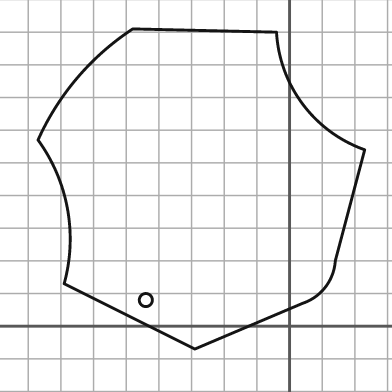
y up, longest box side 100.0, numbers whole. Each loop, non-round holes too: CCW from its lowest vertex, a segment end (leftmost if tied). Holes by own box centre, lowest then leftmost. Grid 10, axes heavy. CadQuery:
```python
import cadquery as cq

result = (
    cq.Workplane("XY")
    .moveTo(-29.0, -7.0)
    .lineTo(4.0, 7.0)
    .threePointArc((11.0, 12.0), (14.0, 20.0))
    .lineTo(23.0, 54.0)
    .threePointArc((4.0, 68.0), (-4.0, 90.0))
    .lineTo(-48.0, 91.0)
    .threePointArc((-65.0, 76.0), (-77.0, 57.0))
    .threePointArc((-68.0, 36.0), (-69.0, 13.0))
    .close()
    .moveTo(-44.0, 8.0)
    .circle(2.0)
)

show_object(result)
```